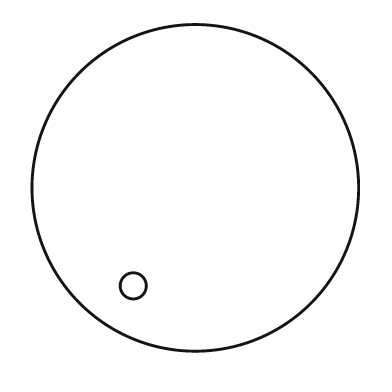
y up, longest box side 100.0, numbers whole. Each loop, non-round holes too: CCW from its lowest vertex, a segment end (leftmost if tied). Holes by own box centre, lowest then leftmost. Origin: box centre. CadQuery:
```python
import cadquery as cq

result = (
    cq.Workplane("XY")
    .moveTo(0.0, 0.0)
    .circle(50.0)
    .moveTo(-19.0, -30.0)
    .circle(4.0)
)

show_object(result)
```